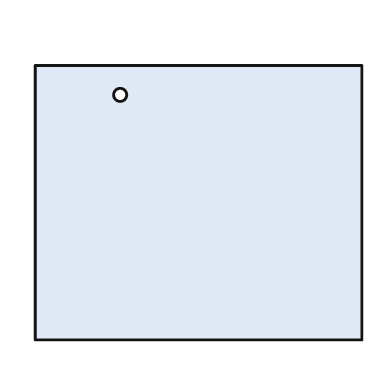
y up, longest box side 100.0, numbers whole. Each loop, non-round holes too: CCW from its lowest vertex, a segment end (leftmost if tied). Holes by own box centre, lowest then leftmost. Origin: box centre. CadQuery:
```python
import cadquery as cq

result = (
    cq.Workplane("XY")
    .moveTo(-50.0, -42.0)
    .lineTo(50.0, -42.0)
    .lineTo(50.0, 42.0)
    .lineTo(-50.0, 42.0)
    .close()
    .moveTo(-24.0, 33.0)
    .circle(2.0)
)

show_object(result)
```